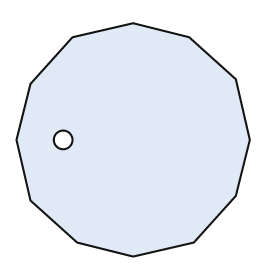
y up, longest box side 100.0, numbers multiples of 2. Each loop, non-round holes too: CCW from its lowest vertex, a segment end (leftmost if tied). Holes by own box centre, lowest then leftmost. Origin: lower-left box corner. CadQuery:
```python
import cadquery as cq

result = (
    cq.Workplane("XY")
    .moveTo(50.0, 0.0)
    .lineTo(76.0, 6.0)
    .lineTo(94.0, 26.0)
    .lineTo(100.0, 50.0)
    .lineTo(94.0, 76.0)
    .lineTo(74.0, 94.0)
    .lineTo(50.0, 100.0)
    .lineTo(24.0, 94.0)
    .lineTo(6.0, 74.0)
    .lineTo(0.0, 50.0)
    .lineTo(6.0, 24.0)
    .lineTo(26.0, 6.0)
    .close()
    .moveTo(20.0, 50.0)
    .circle(4.0)
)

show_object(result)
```